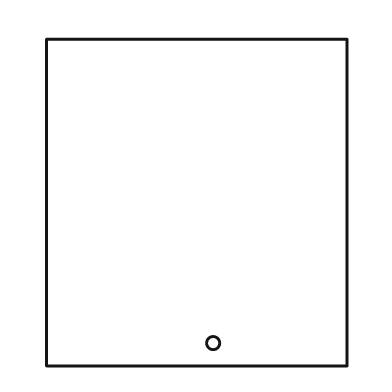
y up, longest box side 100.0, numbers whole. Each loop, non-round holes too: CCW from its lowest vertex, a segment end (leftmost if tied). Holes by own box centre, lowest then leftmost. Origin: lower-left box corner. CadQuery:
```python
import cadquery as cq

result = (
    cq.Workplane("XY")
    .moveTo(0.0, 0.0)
    .lineTo(92.0, 0.0)
    .lineTo(92.0, 100.0)
    .lineTo(0.0, 100.0)
    .close()
    .moveTo(51.0, 7.0)
    .circle(2.0)
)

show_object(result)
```